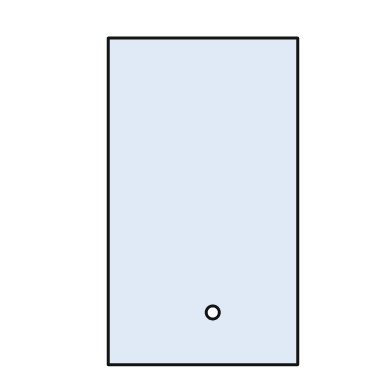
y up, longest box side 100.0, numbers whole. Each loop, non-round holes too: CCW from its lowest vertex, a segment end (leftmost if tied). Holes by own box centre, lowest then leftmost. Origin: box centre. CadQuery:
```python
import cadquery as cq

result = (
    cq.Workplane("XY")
    .moveTo(-29.0, -50.0)
    .lineTo(29.0, -50.0)
    .lineTo(29.0, 50.0)
    .lineTo(-29.0, 50.0)
    .close()
    .moveTo(3.0, -34.0)
    .circle(2.0)
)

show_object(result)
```